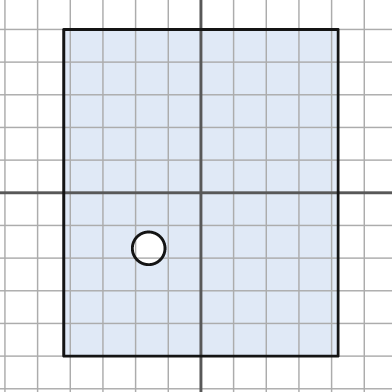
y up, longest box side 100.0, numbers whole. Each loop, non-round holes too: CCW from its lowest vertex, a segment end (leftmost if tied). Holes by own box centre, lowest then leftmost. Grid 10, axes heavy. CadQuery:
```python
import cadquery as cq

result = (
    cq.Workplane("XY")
    .moveTo(-42.0, -50.0)
    .lineTo(42.0, -50.0)
    .lineTo(42.0, 50.0)
    .lineTo(-42.0, 50.0)
    .close()
    .moveTo(-16.0, -17.0)
    .circle(5.0)
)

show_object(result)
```